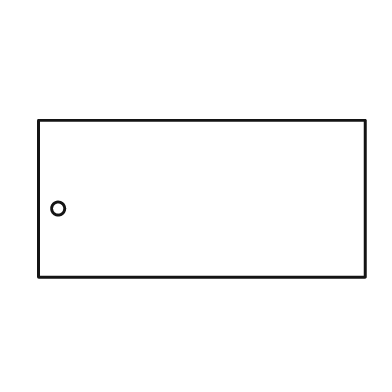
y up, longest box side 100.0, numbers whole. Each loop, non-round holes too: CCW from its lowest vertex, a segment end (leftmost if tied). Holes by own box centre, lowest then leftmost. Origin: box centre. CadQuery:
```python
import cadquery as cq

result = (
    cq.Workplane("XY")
    .moveTo(-50.0, -24.0)
    .lineTo(50.0, -24.0)
    .lineTo(50.0, 24.0)
    .lineTo(-50.0, 24.0)
    .close()
    .moveTo(-44.0, -3.0)
    .circle(2.0)
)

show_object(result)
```